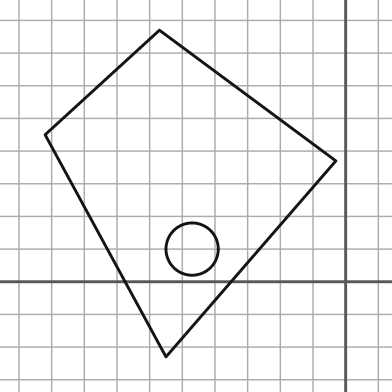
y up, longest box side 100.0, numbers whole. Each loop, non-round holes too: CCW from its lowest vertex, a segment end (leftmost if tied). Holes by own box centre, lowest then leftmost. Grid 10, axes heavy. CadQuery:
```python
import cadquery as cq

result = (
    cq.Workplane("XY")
    .moveTo(-55.0, -23.0)
    .lineTo(-3.0, 37.0)
    .lineTo(-57.0, 77.0)
    .lineTo(-92.0, 45.0)
    .close()
    .moveTo(-47.0, 10.0)
    .circle(8.0)
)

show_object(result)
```